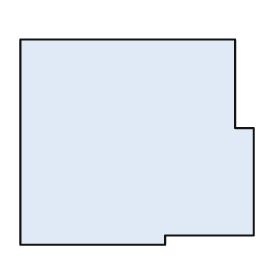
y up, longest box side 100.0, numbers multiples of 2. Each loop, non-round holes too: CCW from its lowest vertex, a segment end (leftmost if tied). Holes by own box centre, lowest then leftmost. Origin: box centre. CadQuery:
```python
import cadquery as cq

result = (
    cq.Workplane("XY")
    .moveTo(-50.0, -44.0)
    .lineTo(12.0, -44.0)
    .lineTo(12.0, -40.0)
    .lineTo(50.0, -40.0)
    .lineTo(50.0, 6.0)
    .lineTo(42.0, 6.0)
    .lineTo(42.0, 44.0)
    .lineTo(-50.0, 44.0)
    .close()
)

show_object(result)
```